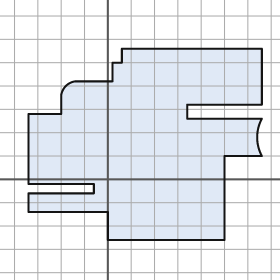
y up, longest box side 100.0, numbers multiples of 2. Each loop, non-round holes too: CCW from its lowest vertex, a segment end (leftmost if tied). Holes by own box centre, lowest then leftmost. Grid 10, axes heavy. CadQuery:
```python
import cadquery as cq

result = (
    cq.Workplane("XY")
    .moveTo(0.0, -26.0)
    .lineTo(50.0, -26.0)
    .lineTo(50.0, 10.0)
    .lineTo(66.0, 10.0)
    .threePointArc((64.0, 18.0), (66.0, 26.0))
    .lineTo(34.0, 26.0)
    .lineTo(34.0, 32.0)
    .lineTo(66.0, 32.0)
    .lineTo(66.0, 56.0)
    .lineTo(6.0, 56.0)
    .lineTo(6.0, 50.0)
    .lineTo(2.0, 50.0)
    .lineTo(2.0, 42.0)
    .lineTo(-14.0, 42.0)
    .threePointArc((-18.0, 40.0), (-20.0, 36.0))
    .lineTo(-20.0, 28.0)
    .lineTo(-34.0, 28.0)
    .lineTo(-34.0, -2.0)
    .lineTo(-6.0, -2.0)
    .lineTo(-6.0, -6.0)
    .lineTo(-34.0, -6.0)
    .lineTo(-34.0, -14.0)
    .lineTo(0.0, -14.0)
    .close()
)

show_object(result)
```